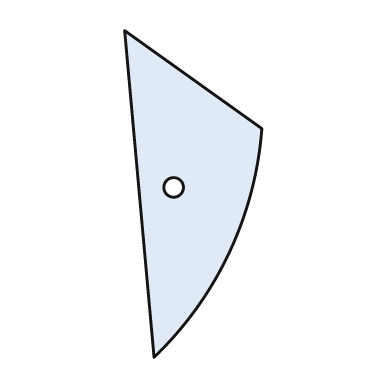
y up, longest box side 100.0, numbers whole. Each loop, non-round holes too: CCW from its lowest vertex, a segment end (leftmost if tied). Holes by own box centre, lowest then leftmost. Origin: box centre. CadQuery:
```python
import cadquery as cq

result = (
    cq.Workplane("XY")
    .moveTo(-12.0, -50.0)
    .threePointArc((11.0, -18.0), (21.0, 20.0))
    .lineTo(-21.0, 50.0)
    .close()
    .moveTo(-6.0, 2.0)
    .circle(3.0)
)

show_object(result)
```